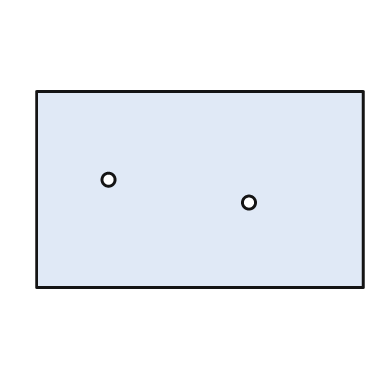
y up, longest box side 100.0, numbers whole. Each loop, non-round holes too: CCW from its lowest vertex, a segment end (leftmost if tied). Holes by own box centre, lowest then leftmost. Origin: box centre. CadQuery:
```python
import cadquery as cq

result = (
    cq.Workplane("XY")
    .moveTo(-50.0, -30.0)
    .lineTo(50.0, -30.0)
    .lineTo(50.0, 30.0)
    .lineTo(-50.0, 30.0)
    .close()
    .moveTo(15.0, -4.0)
    .circle(2.0)
    .moveTo(-28.0, 3.0)
    .circle(2.0)
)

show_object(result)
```